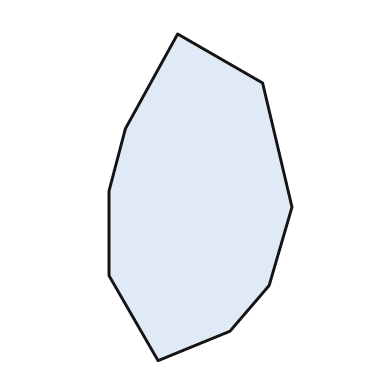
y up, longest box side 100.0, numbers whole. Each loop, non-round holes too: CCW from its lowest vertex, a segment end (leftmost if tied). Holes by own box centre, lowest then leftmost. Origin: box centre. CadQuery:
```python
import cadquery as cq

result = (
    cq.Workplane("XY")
    .moveTo(-13.0, -50.0)
    .lineTo(9.0, -41.0)
    .lineTo(21.0, -27.0)
    .lineTo(28.0, -3.0)
    .lineTo(19.0, 35.0)
    .lineTo(-7.0, 50.0)
    .lineTo(-23.0, 21.0)
    .lineTo(-28.0, 2.0)
    .lineTo(-28.0, -24.0)
    .close()
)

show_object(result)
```